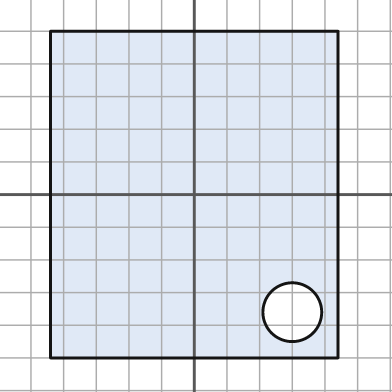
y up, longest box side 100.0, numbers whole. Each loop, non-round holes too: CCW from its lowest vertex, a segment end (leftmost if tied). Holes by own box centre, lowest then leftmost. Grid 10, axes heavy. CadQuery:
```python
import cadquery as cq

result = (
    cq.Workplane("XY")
    .moveTo(-44.0, -50.0)
    .lineTo(44.0, -50.0)
    .lineTo(44.0, 50.0)
    .lineTo(-44.0, 50.0)
    .close()
    .moveTo(30.0, -36.0)
    .circle(9.0)
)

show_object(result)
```